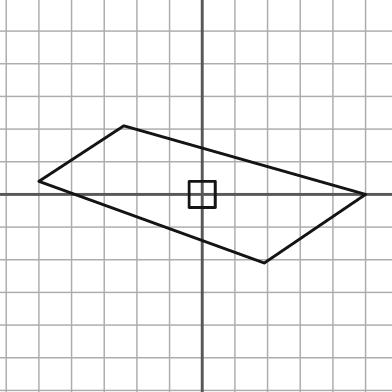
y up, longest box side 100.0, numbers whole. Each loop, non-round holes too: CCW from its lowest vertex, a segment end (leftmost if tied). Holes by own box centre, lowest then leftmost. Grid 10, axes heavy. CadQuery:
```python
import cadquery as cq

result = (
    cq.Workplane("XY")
    .moveTo(19.0, -21.0)
    .lineTo(50.0, 0.0)
    .lineTo(-24.0, 21.0)
    .lineTo(-50.0, 4.0)
    .close()
    .moveTo(-4.0, -4.0)
    .lineTo(4.0, -4.0)
    .lineTo(4.0, 4.0)
    .lineTo(-4.0, 4.0)
    .close()
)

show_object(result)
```